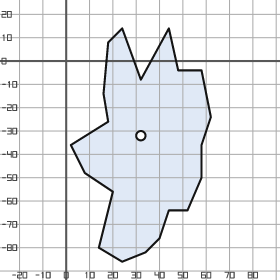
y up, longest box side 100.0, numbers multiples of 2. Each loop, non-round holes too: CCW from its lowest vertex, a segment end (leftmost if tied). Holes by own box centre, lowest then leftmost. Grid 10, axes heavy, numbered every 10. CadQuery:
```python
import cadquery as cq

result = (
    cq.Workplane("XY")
    .moveTo(24.0, -86.0)
    .lineTo(34.0, -82.0)
    .lineTo(40.0, -76.0)
    .lineTo(44.0, -64.0)
    .lineTo(52.0, -64.0)
    .lineTo(58.0, -50.0)
    .lineTo(58.0, -36.0)
    .lineTo(62.0, -24.0)
    .lineTo(58.0, -4.0)
    .lineTo(48.0, -4.0)
    .lineTo(44.0, 14.0)
    .lineTo(32.0, -8.0)
    .lineTo(24.0, 14.0)
    .lineTo(18.0, 8.0)
    .lineTo(16.0, -14.0)
    .lineTo(18.0, -26.0)
    .lineTo(2.0, -36.0)
    .lineTo(8.0, -48.0)
    .lineTo(20.0, -56.0)
    .lineTo(14.0, -80.0)
    .close()
    .moveTo(32.0, -32.0)
    .circle(2.0)
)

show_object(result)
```